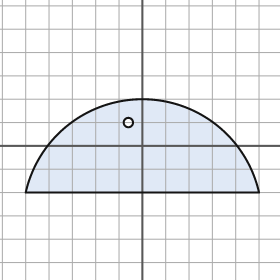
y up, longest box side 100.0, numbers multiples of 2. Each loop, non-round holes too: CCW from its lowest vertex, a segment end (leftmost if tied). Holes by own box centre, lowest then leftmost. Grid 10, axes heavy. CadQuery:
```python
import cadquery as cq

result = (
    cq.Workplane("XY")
    .moveTo(-50.0, -20.0)
    .lineTo(50.0, -20.0)
    .threePointArc((0.0, 20.0), (-50.0, -20.0))
    .close()
    .moveTo(-6.0, 10.0)
    .circle(2.0)
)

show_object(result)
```